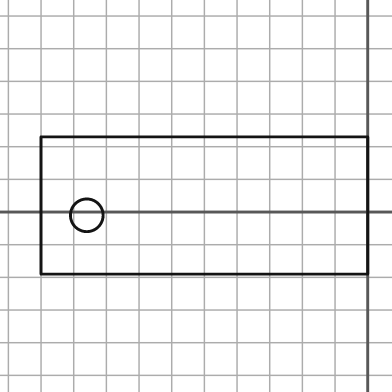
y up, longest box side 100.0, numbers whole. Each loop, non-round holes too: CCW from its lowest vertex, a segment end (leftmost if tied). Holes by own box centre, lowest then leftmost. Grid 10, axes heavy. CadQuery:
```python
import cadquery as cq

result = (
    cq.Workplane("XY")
    .moveTo(-100.0, -19.0)
    .lineTo(0.0, -19.0)
    .lineTo(0.0, 23.0)
    .lineTo(-100.0, 23.0)
    .close()
    .moveTo(-86.0, -1.0)
    .circle(5.0)
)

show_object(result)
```